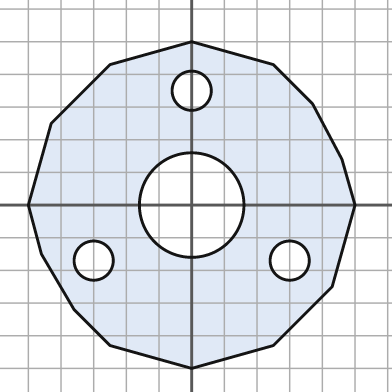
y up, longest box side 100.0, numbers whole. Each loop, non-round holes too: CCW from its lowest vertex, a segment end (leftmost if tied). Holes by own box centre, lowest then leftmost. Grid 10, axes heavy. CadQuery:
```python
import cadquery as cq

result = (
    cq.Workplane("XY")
    .moveTo(0.0, -50.0)
    .lineTo(25.0, -43.0)
    .lineTo(43.0, -25.0)
    .lineTo(50.0, 0.0)
    .lineTo(46.0, 14.0)
    .lineTo(37.0, 31.0)
    .lineTo(25.0, 43.0)
    .lineTo(0.0, 50.0)
    .lineTo(-25.0, 43.0)
    .lineTo(-43.0, 25.0)
    .lineTo(-50.0, 0.0)
    .lineTo(-46.0, -15.0)
    .lineTo(-36.0, -32.0)
    .lineTo(-25.0, -43.0)
    .close()
    .moveTo(-30.0, -17.0)
    .circle(6.0)
    .moveTo(30.0, -17.0)
    .circle(6.0)
    .moveTo(0.0, 0.0)
    .circle(16.0)
    .moveTo(0.0, 35.0)
    .circle(6.0)
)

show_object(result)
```